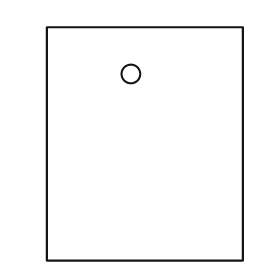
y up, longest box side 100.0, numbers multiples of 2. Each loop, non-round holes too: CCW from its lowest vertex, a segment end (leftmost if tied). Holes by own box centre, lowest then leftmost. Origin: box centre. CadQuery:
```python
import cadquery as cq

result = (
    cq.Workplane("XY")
    .moveTo(-42.0, -50.0)
    .lineTo(42.0, -50.0)
    .lineTo(42.0, 50.0)
    .lineTo(-42.0, 50.0)
    .close()
    .moveTo(-6.0, 30.0)
    .circle(4.0)
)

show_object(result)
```